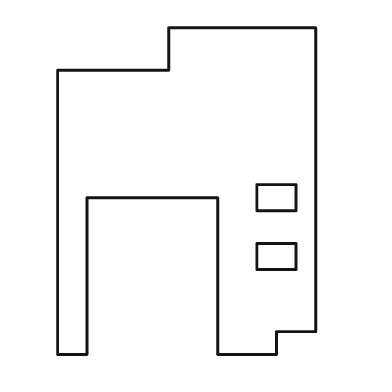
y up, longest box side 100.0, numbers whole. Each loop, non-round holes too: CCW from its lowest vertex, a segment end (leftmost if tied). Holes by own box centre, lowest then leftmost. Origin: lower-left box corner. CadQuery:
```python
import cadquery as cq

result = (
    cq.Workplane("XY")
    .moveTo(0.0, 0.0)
    .lineTo(9.0, 0.0)
    .lineTo(9.0, 48.0)
    .lineTo(49.0, 48.0)
    .lineTo(49.0, 0.0)
    .lineTo(67.0, 0.0)
    .lineTo(67.0, 7.0)
    .lineTo(79.0, 7.0)
    .lineTo(79.0, 100.0)
    .lineTo(34.0, 100.0)
    .lineTo(34.0, 87.0)
    .lineTo(0.0, 87.0)
    .close()
    .moveTo(61.0, 26.0)
    .lineTo(73.0, 26.0)
    .lineTo(73.0, 34.0)
    .lineTo(61.0, 34.0)
    .close()
    .moveTo(61.0, 44.0)
    .lineTo(73.0, 44.0)
    .lineTo(73.0, 52.0)
    .lineTo(61.0, 52.0)
    .close()
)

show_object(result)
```